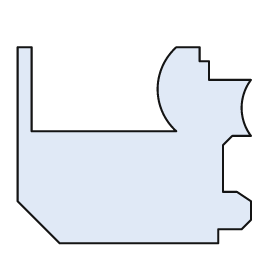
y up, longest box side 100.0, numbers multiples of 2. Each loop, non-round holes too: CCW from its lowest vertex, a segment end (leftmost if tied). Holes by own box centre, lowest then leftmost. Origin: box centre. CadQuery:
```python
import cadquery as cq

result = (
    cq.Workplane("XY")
    .moveTo(-32.0, -42.0)
    .lineTo(36.0, -42.0)
    .lineTo(36.0, -36.0)
    .lineTo(46.0, -36.0)
    .lineTo(50.0, -32.0)
    .lineTo(50.0, -24.0)
    .lineTo(44.0, -20.0)
    .lineTo(38.0, -20.0)
    .lineTo(38.0, 0.0)
    .lineTo(42.0, 4.0)
    .lineTo(50.0, 4.0)
    .threePointArc((46.0, 16.0), (50.0, 28.0))
    .lineTo(32.0, 28.0)
    .lineTo(32.0, 36.0)
    .lineTo(28.0, 36.0)
    .lineTo(28.0, 42.0)
    .lineTo(18.0, 42.0)
    .threePointArc((10.0, 24.0), (18.0, 6.0))
    .lineTo(-44.0, 6.0)
    .lineTo(-44.0, 42.0)
    .lineTo(-50.0, 42.0)
    .lineTo(-50.0, -24.0)
    .close()
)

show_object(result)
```